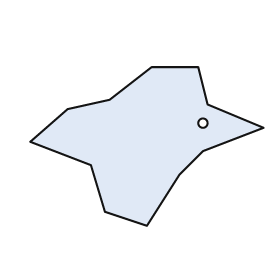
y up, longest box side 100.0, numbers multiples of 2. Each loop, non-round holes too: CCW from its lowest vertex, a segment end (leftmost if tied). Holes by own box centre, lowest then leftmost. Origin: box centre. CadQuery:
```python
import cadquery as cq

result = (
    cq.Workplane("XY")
    .moveTo(0.0, -34.0)
    .lineTo(14.0, -12.0)
    .lineTo(24.0, -2.0)
    .lineTo(50.0, 8.0)
    .lineTo(26.0, 18.0)
    .lineTo(22.0, 34.0)
    .lineTo(2.0, 34.0)
    .lineTo(-16.0, 20.0)
    .lineTo(-34.0, 16.0)
    .lineTo(-50.0, 2.0)
    .lineTo(-24.0, -8.0)
    .lineTo(-18.0, -28.0)
    .close()
    .moveTo(24.0, 10.0)
    .circle(2.0)
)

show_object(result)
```